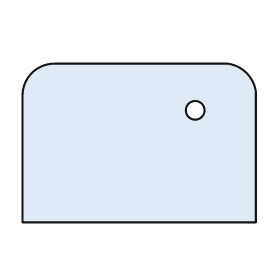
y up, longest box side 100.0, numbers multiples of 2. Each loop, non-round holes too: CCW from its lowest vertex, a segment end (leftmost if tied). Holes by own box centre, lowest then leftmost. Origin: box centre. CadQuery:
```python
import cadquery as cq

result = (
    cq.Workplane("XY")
    .moveTo(-50.0, -34.0)
    .lineTo(50.0, -34.0)
    .lineTo(50.0, 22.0)
    .threePointArc((46.0, 30.0), (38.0, 34.0))
    .lineTo(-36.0, 34.0)
    .threePointArc((-46.0, 30.0), (-50.0, 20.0))
    .close()
    .moveTo(24.0, 14.0)
    .circle(4.0)
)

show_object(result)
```